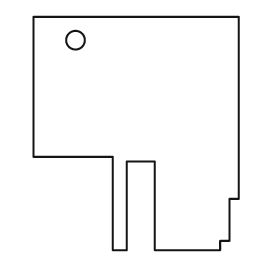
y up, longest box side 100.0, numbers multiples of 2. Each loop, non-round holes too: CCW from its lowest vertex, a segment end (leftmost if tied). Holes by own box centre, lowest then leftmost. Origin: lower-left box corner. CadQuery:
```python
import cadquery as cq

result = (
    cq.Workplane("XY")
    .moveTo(34.0, 0.0)
    .lineTo(40.0, 0.0)
    .lineTo(40.0, 38.0)
    .lineTo(52.0, 38.0)
    .lineTo(52.0, 0.0)
    .lineTo(80.0, 0.0)
    .lineTo(80.0, 4.0)
    .lineTo(84.0, 4.0)
    .lineTo(84.0, 22.0)
    .lineTo(88.0, 22.0)
    .lineTo(88.0, 100.0)
    .lineTo(0.0, 100.0)
    .lineTo(0.0, 40.0)
    .lineTo(34.0, 40.0)
    .close()
    .moveTo(18.0, 90.0)
    .circle(4.0)
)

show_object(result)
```